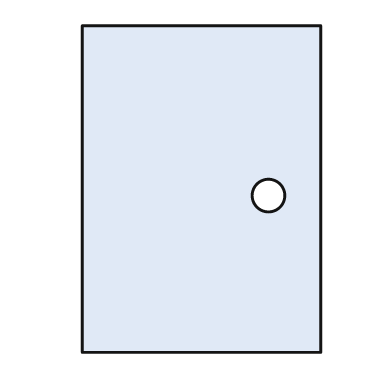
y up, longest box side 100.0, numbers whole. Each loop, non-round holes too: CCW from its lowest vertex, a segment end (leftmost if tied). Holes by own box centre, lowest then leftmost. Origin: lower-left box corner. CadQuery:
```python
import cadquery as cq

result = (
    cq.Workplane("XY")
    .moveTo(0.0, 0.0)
    .lineTo(73.0, 0.0)
    .lineTo(73.0, 100.0)
    .lineTo(0.0, 100.0)
    .close()
    .moveTo(57.0, 48.0)
    .circle(5.0)
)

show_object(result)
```